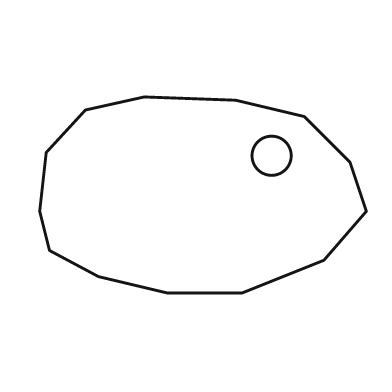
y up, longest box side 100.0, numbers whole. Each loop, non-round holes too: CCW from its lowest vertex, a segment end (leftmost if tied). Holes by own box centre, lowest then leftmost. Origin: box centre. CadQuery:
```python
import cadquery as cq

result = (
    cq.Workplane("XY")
    .moveTo(-11.0, -30.0)
    .lineTo(12.0, -30.0)
    .lineTo(37.0, -20.0)
    .lineTo(50.0, -5.0)
    .lineTo(45.0, 10.0)
    .lineTo(31.0, 24.0)
    .lineTo(10.0, 29.0)
    .lineTo(-18.0, 30.0)
    .lineTo(-36.0, 26.0)
    .lineTo(-48.0, 13.0)
    .lineTo(-50.0, -5.0)
    .lineTo(-47.0, -17.0)
    .lineTo(-32.0, -25.0)
    .close()
    .moveTo(21.0, 12.0)
    .circle(6.0)
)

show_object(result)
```